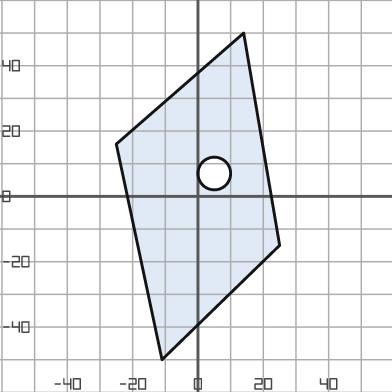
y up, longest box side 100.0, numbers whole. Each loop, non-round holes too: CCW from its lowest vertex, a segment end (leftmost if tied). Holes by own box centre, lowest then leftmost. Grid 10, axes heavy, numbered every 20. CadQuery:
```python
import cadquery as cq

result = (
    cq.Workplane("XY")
    .moveTo(-11.0, -50.0)
    .lineTo(25.0, -15.0)
    .lineTo(14.0, 50.0)
    .lineTo(-25.0, 16.0)
    .close()
    .moveTo(5.0, 7.0)
    .circle(5.0)
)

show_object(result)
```